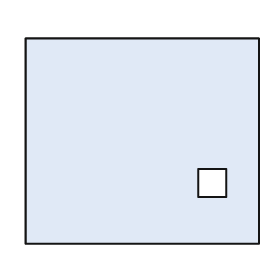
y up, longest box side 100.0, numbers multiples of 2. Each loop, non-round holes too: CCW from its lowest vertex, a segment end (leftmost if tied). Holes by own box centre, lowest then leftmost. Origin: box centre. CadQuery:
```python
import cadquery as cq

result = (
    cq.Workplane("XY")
    .moveTo(-50.0, -44.0)
    .lineTo(50.0, -44.0)
    .lineTo(50.0, 44.0)
    .lineTo(-50.0, 44.0)
    .close()
    .moveTo(24.0, -24.0)
    .lineTo(36.0, -24.0)
    .lineTo(36.0, -12.0)
    .lineTo(24.0, -12.0)
    .close()
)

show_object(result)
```